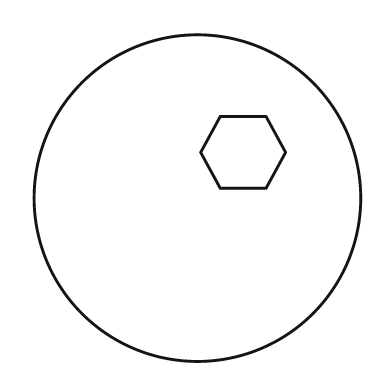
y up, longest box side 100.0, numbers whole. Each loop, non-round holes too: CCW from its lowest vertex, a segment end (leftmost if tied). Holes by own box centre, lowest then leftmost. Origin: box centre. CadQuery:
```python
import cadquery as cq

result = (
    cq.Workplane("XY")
    .moveTo(0.0, 0.0)
    .circle(50.0)
    .moveTo(7.0, 3.0)
    .lineTo(21.0, 3.0)
    .lineTo(27.0, 14.0)
    .lineTo(21.0, 25.0)
    .lineTo(7.0, 25.0)
    .lineTo(1.0, 14.0)
    .close()
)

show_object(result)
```